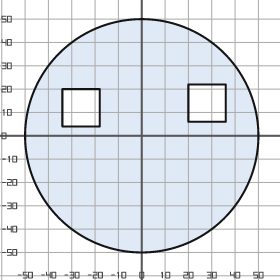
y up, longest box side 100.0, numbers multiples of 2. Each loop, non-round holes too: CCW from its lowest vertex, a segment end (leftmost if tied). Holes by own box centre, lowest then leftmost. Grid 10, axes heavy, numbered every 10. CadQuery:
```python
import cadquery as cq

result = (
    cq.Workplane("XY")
    .moveTo(0.0, 0.0)
    .circle(50.0)
    .moveTo(-34.0, 4.0)
    .lineTo(-18.0, 4.0)
    .lineTo(-18.0, 20.0)
    .lineTo(-34.0, 20.0)
    .close()
    .moveTo(20.0, 6.0)
    .lineTo(36.0, 6.0)
    .lineTo(36.0, 22.0)
    .lineTo(20.0, 22.0)
    .close()
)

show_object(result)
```